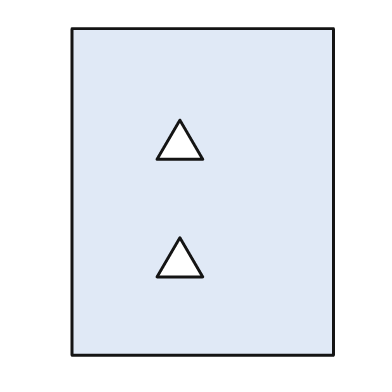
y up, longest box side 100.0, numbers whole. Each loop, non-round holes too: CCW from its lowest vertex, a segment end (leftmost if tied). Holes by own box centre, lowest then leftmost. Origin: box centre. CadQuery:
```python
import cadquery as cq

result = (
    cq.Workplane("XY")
    .moveTo(-40.0, -50.0)
    .lineTo(40.0, -50.0)
    .lineTo(40.0, 50.0)
    .lineTo(-40.0, 50.0)
    .close()
    .moveTo(-14.0, -26.0)
    .lineTo(0.0, -26.0)
    .lineTo(-7.0, -14.0)
    .close()
    .moveTo(-14.0, 10.0)
    .lineTo(0.0, 10.0)
    .lineTo(-7.0, 22.0)
    .close()
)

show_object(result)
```